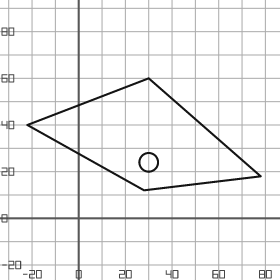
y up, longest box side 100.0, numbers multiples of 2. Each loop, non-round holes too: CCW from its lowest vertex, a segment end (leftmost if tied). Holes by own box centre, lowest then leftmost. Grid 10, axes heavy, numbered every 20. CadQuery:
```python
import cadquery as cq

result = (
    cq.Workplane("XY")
    .moveTo(28.0, 12.0)
    .lineTo(78.0, 18.0)
    .lineTo(30.0, 60.0)
    .lineTo(-22.0, 40.0)
    .close()
    .moveTo(30.0, 24.0)
    .circle(4.0)
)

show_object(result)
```